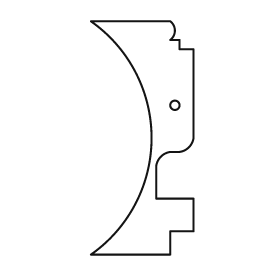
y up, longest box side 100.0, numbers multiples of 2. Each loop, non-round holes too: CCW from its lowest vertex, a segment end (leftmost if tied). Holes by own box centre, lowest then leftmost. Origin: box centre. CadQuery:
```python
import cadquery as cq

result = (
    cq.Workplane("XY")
    .moveTo(-22.0, -50.0)
    .lineTo(12.0, -50.0)
    .lineTo(12.0, -40.0)
    .lineTo(22.0, -40.0)
    .lineTo(22.0, -26.0)
    .lineTo(6.0, -26.0)
    .lineTo(6.0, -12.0)
    .threePointArc((8.0, -8.0), (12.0, -6.0))
    .lineTo(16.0, -6.0)
    .threePointArc((20.0, -4.0), (22.0, 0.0))
    .lineTo(22.0, 38.0)
    .lineTo(16.0, 38.0)
    .lineTo(16.0, 42.0)
    .lineTo(12.0, 42.0)
    .threePointArc((14.0, 46.0), (12.0, 50.0))
    .lineTo(-22.0, 50.0)
    .threePointArc((4.0, 0.0), (-22.0, -50.0))
    .close()
    .moveTo(14.0, 14.0)
    .circle(2.0)
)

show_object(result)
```